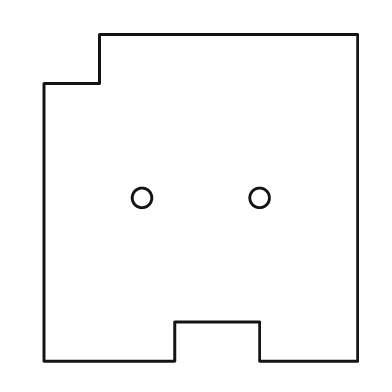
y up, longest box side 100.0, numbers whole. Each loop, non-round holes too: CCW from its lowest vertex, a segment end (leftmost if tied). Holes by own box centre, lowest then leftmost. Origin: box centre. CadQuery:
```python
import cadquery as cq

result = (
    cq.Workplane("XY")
    .moveTo(-48.0, -50.0)
    .lineTo(-8.0, -50.0)
    .lineTo(-8.0, -38.0)
    .lineTo(18.0, -38.0)
    .lineTo(18.0, -50.0)
    .lineTo(48.0, -50.0)
    .lineTo(48.0, 50.0)
    .lineTo(-31.0, 50.0)
    .lineTo(-31.0, 35.0)
    .lineTo(-48.0, 35.0)
    .close()
    .moveTo(-18.0, 0.0)
    .circle(3.0)
    .moveTo(18.0, 0.0)
    .circle(3.0)
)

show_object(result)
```